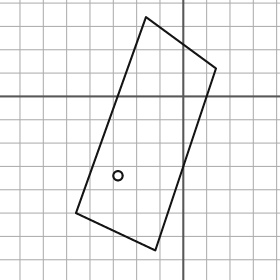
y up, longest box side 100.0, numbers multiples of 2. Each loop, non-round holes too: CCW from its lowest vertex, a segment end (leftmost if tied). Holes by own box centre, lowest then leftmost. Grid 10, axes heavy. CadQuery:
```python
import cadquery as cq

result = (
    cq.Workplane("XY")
    .moveTo(-12.0, -66.0)
    .lineTo(14.0, 12.0)
    .lineTo(-16.0, 34.0)
    .lineTo(-46.0, -50.0)
    .close()
    .moveTo(-28.0, -34.0)
    .circle(2.0)
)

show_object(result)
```